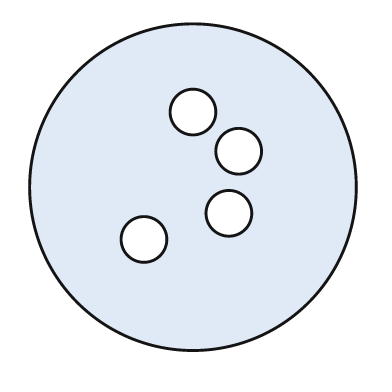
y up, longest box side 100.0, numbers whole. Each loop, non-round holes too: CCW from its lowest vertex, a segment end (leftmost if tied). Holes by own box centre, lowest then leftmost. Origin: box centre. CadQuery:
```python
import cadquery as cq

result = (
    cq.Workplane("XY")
    .moveTo(0.0, 0.0)
    .circle(50.0)
    .moveTo(-15.0, -16.0)
    .circle(7.0)
    .moveTo(11.0, -8.0)
    .circle(7.0)
    .moveTo(14.0, 11.0)
    .circle(7.0)
    .moveTo(0.0, 23.0)
    .circle(7.0)
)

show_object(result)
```